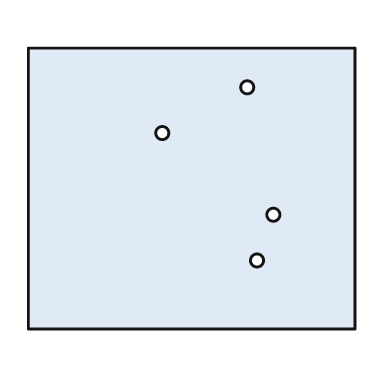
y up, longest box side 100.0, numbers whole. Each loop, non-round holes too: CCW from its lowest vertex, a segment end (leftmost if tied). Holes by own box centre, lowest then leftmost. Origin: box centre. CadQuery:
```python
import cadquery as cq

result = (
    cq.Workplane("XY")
    .moveTo(-50.0, -43.0)
    .lineTo(50.0, -43.0)
    .lineTo(50.0, 43.0)
    .lineTo(-50.0, 43.0)
    .close()
    .moveTo(20.0, -22.0)
    .circle(2.0)
    .moveTo(25.0, -8.0)
    .circle(2.0)
    .moveTo(-9.0, 17.0)
    .circle(2.0)
    .moveTo(17.0, 31.0)
    .circle(2.0)
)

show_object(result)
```